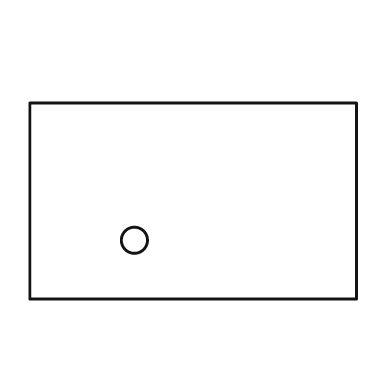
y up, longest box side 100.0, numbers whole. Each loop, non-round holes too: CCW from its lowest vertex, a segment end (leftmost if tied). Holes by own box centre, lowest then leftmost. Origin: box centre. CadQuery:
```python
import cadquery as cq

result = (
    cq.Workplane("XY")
    .moveTo(-50.0, -30.0)
    .lineTo(50.0, -30.0)
    .lineTo(50.0, 30.0)
    .lineTo(-50.0, 30.0)
    .close()
    .moveTo(-18.0, -12.0)
    .circle(4.0)
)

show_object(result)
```